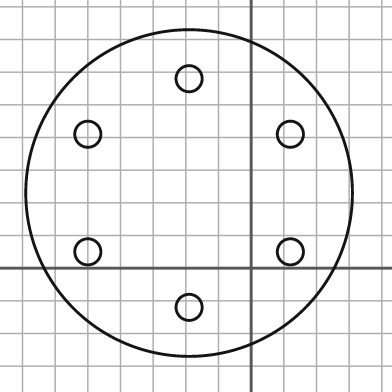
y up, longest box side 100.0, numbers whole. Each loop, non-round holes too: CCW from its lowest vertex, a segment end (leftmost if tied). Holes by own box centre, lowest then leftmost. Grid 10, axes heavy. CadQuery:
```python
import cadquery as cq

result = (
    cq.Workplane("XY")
    .moveTo(-19.0, 23.0)
    .circle(50.0)
    .moveTo(-19.0, -12.0)
    .circle(4.0)
    .moveTo(-50.0, 5.0)
    .circle(4.0)
    .moveTo(12.0, 5.0)
    .circle(4.0)
    .moveTo(-50.0, 41.0)
    .circle(4.0)
    .moveTo(12.0, 41.0)
    .circle(4.0)
    .moveTo(-19.0, 58.0)
    .circle(4.0)
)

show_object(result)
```